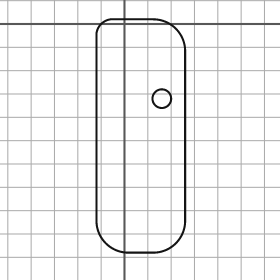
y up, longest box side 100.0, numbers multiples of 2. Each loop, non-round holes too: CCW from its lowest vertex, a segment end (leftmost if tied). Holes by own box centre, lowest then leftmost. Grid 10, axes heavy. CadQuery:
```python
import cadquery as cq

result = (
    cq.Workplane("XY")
    .moveTo(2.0, -98.0)
    .lineTo(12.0, -98.0)
    .threePointArc((22.0, -94.0), (26.0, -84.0))
    .lineTo(26.0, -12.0)
    .threePointArc((22.0, -2.0), (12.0, 2.0))
    .lineTo(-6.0, 2.0)
    .threePointArc((-10.0, 0.0), (-12.0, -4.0))
    .lineTo(-12.0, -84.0)
    .threePointArc((-8.0, -94.0), (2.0, -98.0))
    .close()
    .moveTo(16.0, -32.0)
    .circle(4.0)
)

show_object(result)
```